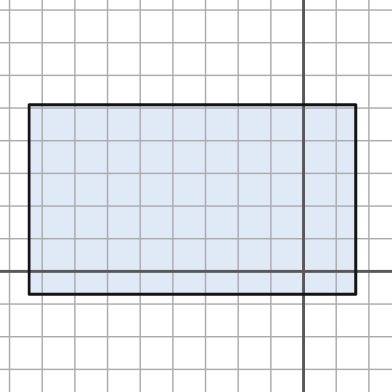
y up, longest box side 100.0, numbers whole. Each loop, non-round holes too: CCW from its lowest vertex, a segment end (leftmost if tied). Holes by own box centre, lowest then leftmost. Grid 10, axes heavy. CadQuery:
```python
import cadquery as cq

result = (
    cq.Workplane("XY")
    .moveTo(-84.0, -7.0)
    .lineTo(16.0, -7.0)
    .lineTo(16.0, 51.0)
    .lineTo(-84.0, 51.0)
    .close()
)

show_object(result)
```